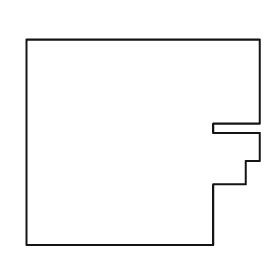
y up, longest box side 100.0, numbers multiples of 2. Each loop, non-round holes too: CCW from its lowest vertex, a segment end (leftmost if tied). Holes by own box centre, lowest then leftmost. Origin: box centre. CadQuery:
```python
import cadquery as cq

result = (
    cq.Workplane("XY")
    .moveTo(-50.0, -44.0)
    .lineTo(30.0, -44.0)
    .lineTo(30.0, -18.0)
    .lineTo(44.0, -18.0)
    .lineTo(44.0, -8.0)
    .lineTo(50.0, -8.0)
    .lineTo(50.0, 4.0)
    .lineTo(30.0, 4.0)
    .lineTo(30.0, 8.0)
    .lineTo(50.0, 8.0)
    .lineTo(50.0, 44.0)
    .lineTo(-50.0, 44.0)
    .close()
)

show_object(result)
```